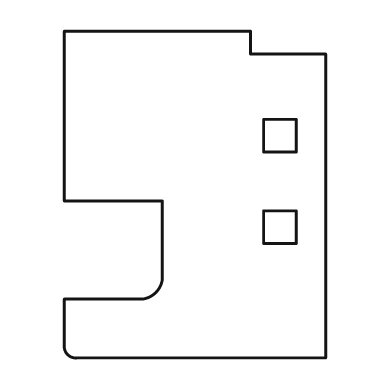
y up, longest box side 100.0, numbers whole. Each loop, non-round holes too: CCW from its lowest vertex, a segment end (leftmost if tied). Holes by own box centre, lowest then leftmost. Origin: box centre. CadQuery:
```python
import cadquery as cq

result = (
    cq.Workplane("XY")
    .moveTo(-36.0, -50.0)
    .lineTo(40.0, -50.0)
    .lineTo(40.0, 43.0)
    .lineTo(17.0, 43.0)
    .lineTo(17.0, 50.0)
    .lineTo(-40.0, 50.0)
    .lineTo(-40.0, -2.0)
    .lineTo(-10.0, -2.0)
    .lineTo(-10.0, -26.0)
    .threePointArc((-12.0, -30.0), (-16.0, -32.0))
    .lineTo(-40.0, -32.0)
    .lineTo(-40.0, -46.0)
    .threePointArc((-39.0, -49.0), (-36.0, -50.0))
    .close()
    .moveTo(21.0, -15.0)
    .lineTo(31.0, -15.0)
    .lineTo(31.0, -5.0)
    .lineTo(21.0, -5.0)
    .close()
    .moveTo(21.0, 13.0)
    .lineTo(31.0, 13.0)
    .lineTo(31.0, 23.0)
    .lineTo(21.0, 23.0)
    .close()
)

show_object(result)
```